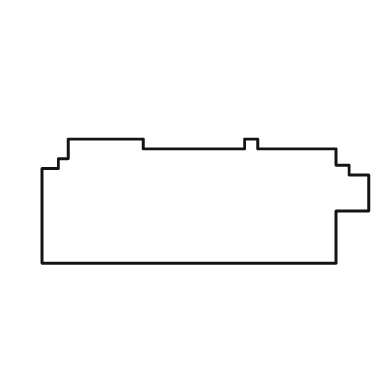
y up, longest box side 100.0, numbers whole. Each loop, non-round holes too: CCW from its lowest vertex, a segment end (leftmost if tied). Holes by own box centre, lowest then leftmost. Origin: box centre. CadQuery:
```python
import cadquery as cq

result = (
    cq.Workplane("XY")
    .moveTo(-50.0, -19.0)
    .lineTo(40.0, -19.0)
    .lineTo(40.0, -3.0)
    .lineTo(50.0, -3.0)
    .lineTo(50.0, 8.0)
    .lineTo(44.0, 8.0)
    .lineTo(44.0, 11.0)
    .lineTo(40.0, 11.0)
    .lineTo(40.0, 16.0)
    .lineTo(16.0, 16.0)
    .lineTo(16.0, 19.0)
    .lineTo(12.0, 19.0)
    .lineTo(12.0, 16.0)
    .lineTo(-19.0, 16.0)
    .lineTo(-19.0, 19.0)
    .lineTo(-42.0, 19.0)
    .lineTo(-42.0, 13.0)
    .lineTo(-45.0, 13.0)
    .lineTo(-45.0, 10.0)
    .lineTo(-50.0, 10.0)
    .close()
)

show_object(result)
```